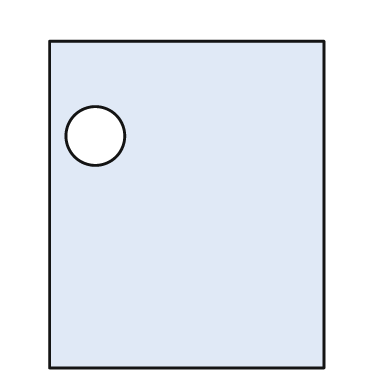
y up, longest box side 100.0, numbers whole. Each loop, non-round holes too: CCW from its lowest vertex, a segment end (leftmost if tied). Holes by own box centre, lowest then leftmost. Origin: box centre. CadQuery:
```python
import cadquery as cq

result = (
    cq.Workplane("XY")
    .moveTo(-42.0, -50.0)
    .lineTo(42.0, -50.0)
    .lineTo(42.0, 50.0)
    .lineTo(-42.0, 50.0)
    .close()
    .moveTo(-28.0, 21.0)
    .circle(9.0)
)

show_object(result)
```